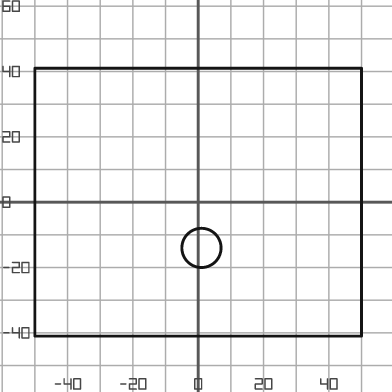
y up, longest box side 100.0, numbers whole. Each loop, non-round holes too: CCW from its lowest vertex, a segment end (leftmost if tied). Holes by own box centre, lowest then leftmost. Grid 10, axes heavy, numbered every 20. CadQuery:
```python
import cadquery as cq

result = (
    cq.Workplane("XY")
    .moveTo(-50.0, -41.0)
    .lineTo(50.0, -41.0)
    .lineTo(50.0, 41.0)
    .lineTo(-50.0, 41.0)
    .close()
    .moveTo(1.0, -14.0)
    .circle(6.0)
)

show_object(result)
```